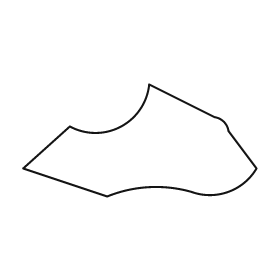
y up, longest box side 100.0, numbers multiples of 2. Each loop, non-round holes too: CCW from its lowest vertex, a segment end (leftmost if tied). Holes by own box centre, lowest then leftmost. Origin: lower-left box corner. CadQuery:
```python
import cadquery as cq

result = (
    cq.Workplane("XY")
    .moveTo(36.0, 0.0)
    .threePointArc((54.0, 4.0), (72.0, 2.0))
    .threePointArc((88.0, 2.0), (100.0, 12.0))
    .lineTo(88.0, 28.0)
    .threePointArc((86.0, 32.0), (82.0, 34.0))
    .lineTo(54.0, 48.0)
    .threePointArc((42.0, 30.0), (20.0, 30.0))
    .lineTo(0.0, 12.0)
    .close()
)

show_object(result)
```